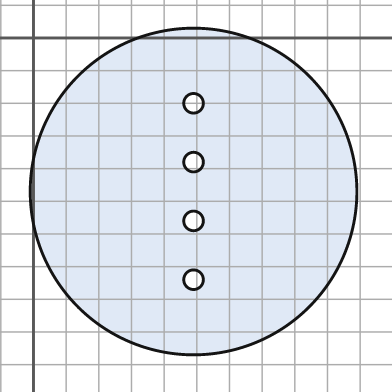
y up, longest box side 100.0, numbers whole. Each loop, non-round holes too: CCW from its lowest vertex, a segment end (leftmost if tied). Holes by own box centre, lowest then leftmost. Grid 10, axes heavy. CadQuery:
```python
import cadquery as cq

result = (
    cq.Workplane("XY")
    .moveTo(49.0, -47.0)
    .circle(50.0)
    .moveTo(49.0, -74.0)
    .circle(3.0)
    .moveTo(49.0, -56.0)
    .circle(3.0)
    .moveTo(49.0, -38.0)
    .circle(3.0)
    .moveTo(49.0, -20.0)
    .circle(3.0)
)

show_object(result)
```